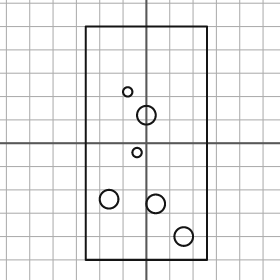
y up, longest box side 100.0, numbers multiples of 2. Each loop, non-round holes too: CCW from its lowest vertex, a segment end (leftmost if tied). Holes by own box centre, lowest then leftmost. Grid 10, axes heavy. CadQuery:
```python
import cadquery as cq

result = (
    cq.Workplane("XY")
    .moveTo(-26.0, -50.0)
    .lineTo(26.0, -50.0)
    .lineTo(26.0, 50.0)
    .lineTo(-26.0, 50.0)
    .close()
    .moveTo(16.0, -40.0)
    .circle(4.0)
    .moveTo(4.0, -26.0)
    .circle(4.0)
    .moveTo(-16.0, -24.0)
    .circle(4.0)
    .moveTo(-4.0, -4.0)
    .circle(2.0)
    .moveTo(0.0, 12.0)
    .circle(4.0)
    .moveTo(-8.0, 22.0)
    .circle(2.0)
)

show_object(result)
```